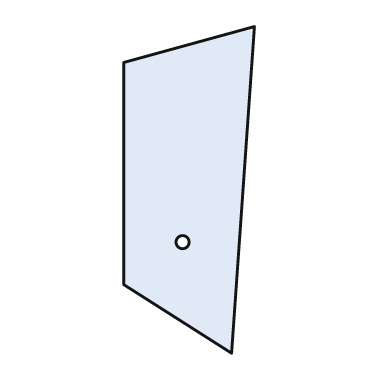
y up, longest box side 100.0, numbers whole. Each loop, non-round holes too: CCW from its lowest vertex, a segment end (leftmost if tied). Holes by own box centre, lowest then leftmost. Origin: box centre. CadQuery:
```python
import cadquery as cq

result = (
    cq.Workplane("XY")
    .moveTo(13.0, -50.0)
    .lineTo(20.0, 50.0)
    .lineTo(-20.0, 39.0)
    .lineTo(-20.0, -29.0)
    .close()
    .moveTo(-2.0, -16.0)
    .circle(2.0)
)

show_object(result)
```